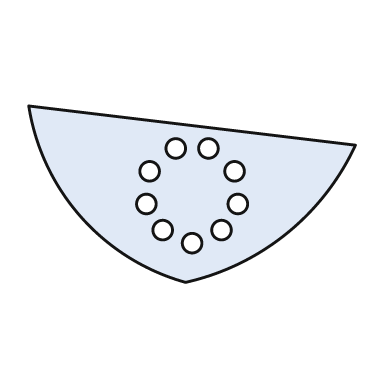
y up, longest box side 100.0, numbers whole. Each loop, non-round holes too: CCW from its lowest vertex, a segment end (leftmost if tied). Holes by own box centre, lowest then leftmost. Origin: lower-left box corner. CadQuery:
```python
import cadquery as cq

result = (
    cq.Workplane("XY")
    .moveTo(48.0, 0.0)
    .threePointArc((79.0, 15.0), (100.0, 42.0))
    .lineTo(0.0, 54.0)
    .threePointArc((16.0, 20.0), (48.0, 0.0))
    .close()
    .moveTo(50.0, 12.0)
    .circle(3.0)
    .moveTo(41.0, 16.0)
    .circle(3.0)
    .moveTo(59.0, 16.0)
    .circle(3.0)
    .moveTo(36.0, 24.0)
    .circle(3.0)
    .moveTo(64.0, 24.0)
    .circle(3.0)
    .moveTo(37.0, 34.0)
    .circle(3.0)
    .moveTo(63.0, 34.0)
    .circle(3.0)
    .moveTo(45.0, 41.0)
    .circle(3.0)
    .moveTo(55.0, 41.0)
    .circle(3.0)
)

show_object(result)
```